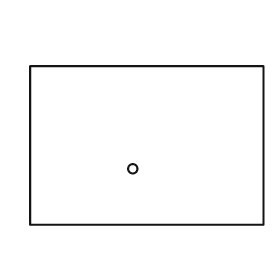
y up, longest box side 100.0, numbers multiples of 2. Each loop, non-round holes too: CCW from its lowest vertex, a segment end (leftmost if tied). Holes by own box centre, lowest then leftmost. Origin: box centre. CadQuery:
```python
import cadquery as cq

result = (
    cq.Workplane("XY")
    .moveTo(-50.0, -34.0)
    .lineTo(50.0, -34.0)
    .lineTo(50.0, 34.0)
    .lineTo(-50.0, 34.0)
    .close()
    .moveTo(-6.0, -10.0)
    .circle(2.0)
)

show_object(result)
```